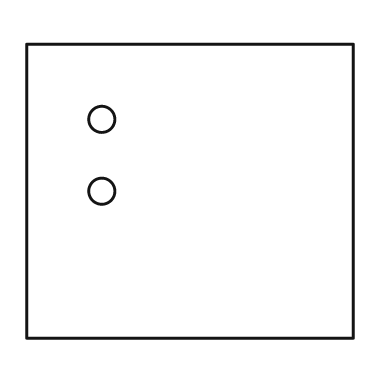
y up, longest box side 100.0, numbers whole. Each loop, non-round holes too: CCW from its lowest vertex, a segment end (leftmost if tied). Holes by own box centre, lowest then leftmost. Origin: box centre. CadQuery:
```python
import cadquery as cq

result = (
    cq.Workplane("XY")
    .moveTo(-50.0, -45.0)
    .lineTo(50.0, -45.0)
    .lineTo(50.0, 45.0)
    .lineTo(-50.0, 45.0)
    .close()
    .moveTo(-27.0, 0.0)
    .circle(4.0)
    .moveTo(-27.0, 22.0)
    .circle(4.0)
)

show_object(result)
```